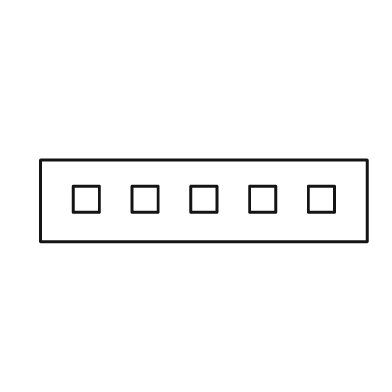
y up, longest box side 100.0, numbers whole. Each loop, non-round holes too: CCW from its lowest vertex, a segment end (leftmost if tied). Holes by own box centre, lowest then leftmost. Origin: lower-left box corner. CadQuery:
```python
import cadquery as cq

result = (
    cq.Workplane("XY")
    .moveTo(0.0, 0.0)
    .lineTo(100.0, 0.0)
    .lineTo(100.0, 25.0)
    .lineTo(0.0, 25.0)
    .close()
    .moveTo(10.0, 9.0)
    .lineTo(18.0, 9.0)
    .lineTo(18.0, 17.0)
    .lineTo(10.0, 17.0)
    .close()
    .moveTo(28.0, 9.0)
    .lineTo(36.0, 9.0)
    .lineTo(36.0, 17.0)
    .lineTo(28.0, 17.0)
    .close()
    .moveTo(46.0, 9.0)
    .lineTo(54.0, 9.0)
    .lineTo(54.0, 17.0)
    .lineTo(46.0, 17.0)
    .close()
    .moveTo(64.0, 9.0)
    .lineTo(72.0, 9.0)
    .lineTo(72.0, 17.0)
    .lineTo(64.0, 17.0)
    .close()
    .moveTo(82.0, 9.0)
    .lineTo(90.0, 9.0)
    .lineTo(90.0, 17.0)
    .lineTo(82.0, 17.0)
    .close()
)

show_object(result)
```